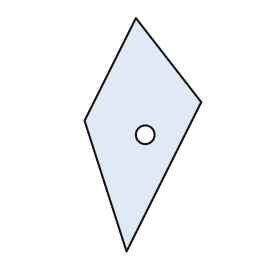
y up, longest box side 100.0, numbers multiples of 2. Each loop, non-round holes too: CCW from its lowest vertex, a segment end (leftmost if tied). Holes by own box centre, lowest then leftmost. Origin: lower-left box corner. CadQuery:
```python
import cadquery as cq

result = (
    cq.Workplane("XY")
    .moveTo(18.0, 0.0)
    .lineTo(50.0, 64.0)
    .lineTo(22.0, 100.0)
    .lineTo(0.0, 56.0)
    .close()
    .moveTo(26.0, 50.0)
    .circle(4.0)
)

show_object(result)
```